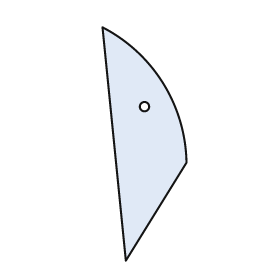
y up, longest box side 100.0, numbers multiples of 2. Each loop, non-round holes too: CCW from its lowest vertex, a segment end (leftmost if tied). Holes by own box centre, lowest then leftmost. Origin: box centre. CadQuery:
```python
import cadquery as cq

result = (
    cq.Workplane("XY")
    .moveTo(-8.0, -50.0)
    .lineTo(18.0, -8.0)
    .threePointArc((8.0, 26.0), (-18.0, 50.0))
    .close()
    .moveTo(0.0, 16.0)
    .circle(2.0)
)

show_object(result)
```